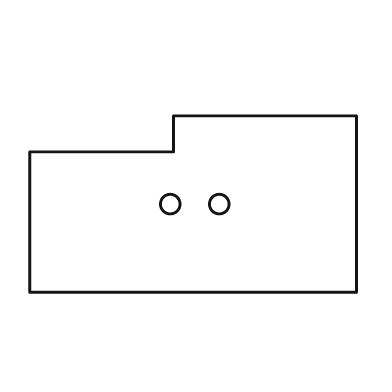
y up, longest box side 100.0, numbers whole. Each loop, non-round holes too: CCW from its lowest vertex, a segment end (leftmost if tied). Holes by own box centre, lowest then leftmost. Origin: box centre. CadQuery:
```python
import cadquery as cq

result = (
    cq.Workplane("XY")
    .moveTo(-50.0, -27.0)
    .lineTo(50.0, -27.0)
    .lineTo(50.0, 27.0)
    .lineTo(-6.0, 27.0)
    .lineTo(-6.0, 16.0)
    .lineTo(-50.0, 16.0)
    .close()
    .moveTo(-7.0, 0.0)
    .circle(3.0)
    .moveTo(8.0, 0.0)
    .circle(3.0)
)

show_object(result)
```